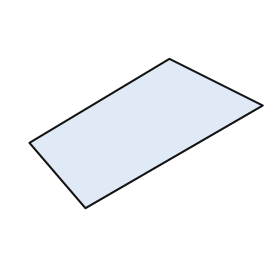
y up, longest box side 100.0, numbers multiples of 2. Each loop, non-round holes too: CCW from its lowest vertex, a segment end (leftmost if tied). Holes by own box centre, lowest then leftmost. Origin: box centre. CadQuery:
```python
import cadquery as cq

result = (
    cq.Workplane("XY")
    .moveTo(-26.0, -32.0)
    .lineTo(50.0, 12.0)
    .lineTo(10.0, 32.0)
    .lineTo(-50.0, -4.0)
    .close()
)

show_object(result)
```